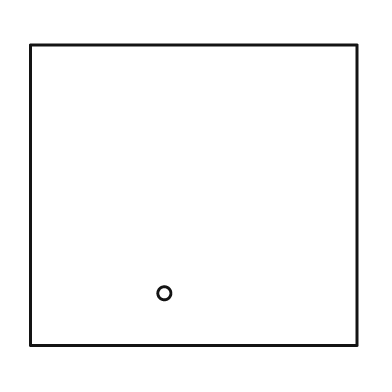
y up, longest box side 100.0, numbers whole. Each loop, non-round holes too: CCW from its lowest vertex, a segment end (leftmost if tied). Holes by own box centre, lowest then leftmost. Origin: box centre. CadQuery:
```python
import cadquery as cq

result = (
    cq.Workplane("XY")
    .moveTo(-50.0, -46.0)
    .lineTo(50.0, -46.0)
    .lineTo(50.0, 46.0)
    .lineTo(-50.0, 46.0)
    .close()
    .moveTo(-9.0, -30.0)
    .circle(2.0)
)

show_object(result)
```